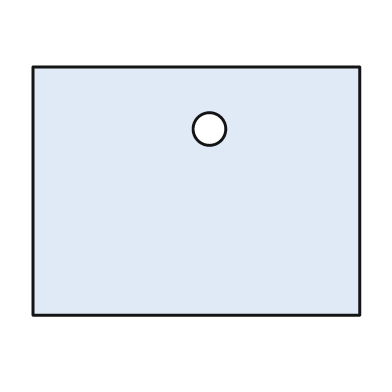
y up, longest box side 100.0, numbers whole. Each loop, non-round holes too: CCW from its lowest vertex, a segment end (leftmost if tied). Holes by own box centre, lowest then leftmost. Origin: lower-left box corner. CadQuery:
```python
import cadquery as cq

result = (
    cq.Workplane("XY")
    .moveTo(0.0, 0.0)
    .lineTo(100.0, 0.0)
    .lineTo(100.0, 76.0)
    .lineTo(0.0, 76.0)
    .close()
    .moveTo(54.0, 57.0)
    .circle(5.0)
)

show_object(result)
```